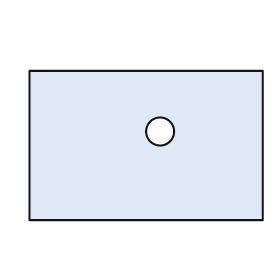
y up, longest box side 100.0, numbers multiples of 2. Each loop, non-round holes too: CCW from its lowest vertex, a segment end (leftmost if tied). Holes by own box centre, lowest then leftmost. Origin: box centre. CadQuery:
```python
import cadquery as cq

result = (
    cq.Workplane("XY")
    .moveTo(-50.0, -32.0)
    .lineTo(50.0, -32.0)
    .lineTo(50.0, 32.0)
    .lineTo(-50.0, 32.0)
    .close()
    .moveTo(6.0, 6.0)
    .circle(6.0)
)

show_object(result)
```